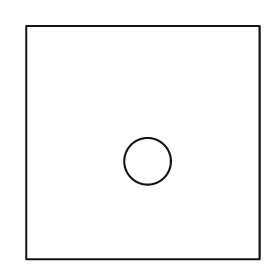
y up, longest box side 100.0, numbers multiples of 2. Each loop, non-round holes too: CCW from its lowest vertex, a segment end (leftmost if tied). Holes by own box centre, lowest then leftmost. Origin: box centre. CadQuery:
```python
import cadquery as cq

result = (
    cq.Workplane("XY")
    .moveTo(-50.0, -50.0)
    .lineTo(50.0, -50.0)
    .lineTo(50.0, 50.0)
    .lineTo(-50.0, 50.0)
    .close()
    .moveTo(2.0, -8.0)
    .circle(10.0)
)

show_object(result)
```